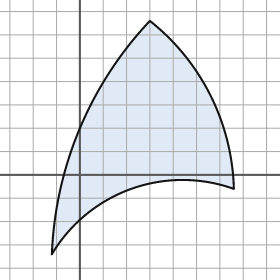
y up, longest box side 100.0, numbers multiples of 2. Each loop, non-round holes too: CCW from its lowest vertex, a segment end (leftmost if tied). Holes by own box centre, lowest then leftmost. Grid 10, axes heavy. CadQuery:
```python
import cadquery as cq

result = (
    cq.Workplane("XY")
    .moveTo(-12.0, -34.0)
    .threePointArc((22.0, -6.0), (66.0, -6.0))
    .threePointArc((56.0, 34.0), (30.0, 66.0))
    .threePointArc((0.0, 20.0), (-12.0, -34.0))
    .close()
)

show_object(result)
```